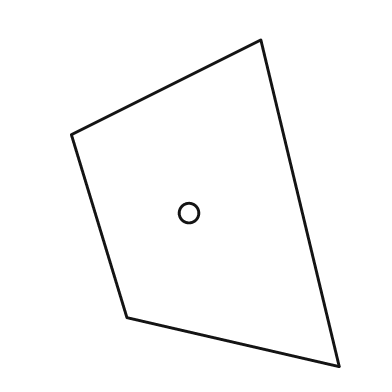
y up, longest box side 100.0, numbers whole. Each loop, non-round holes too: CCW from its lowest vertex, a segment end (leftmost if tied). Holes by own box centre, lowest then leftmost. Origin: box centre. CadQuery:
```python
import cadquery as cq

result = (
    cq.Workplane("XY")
    .moveTo(41.0, -50.0)
    .lineTo(17.0, 50.0)
    .lineTo(-41.0, 21.0)
    .lineTo(-24.0, -35.0)
    .close()
    .moveTo(-5.0, -3.0)
    .circle(3.0)
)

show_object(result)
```